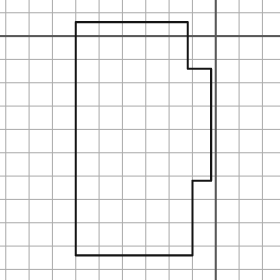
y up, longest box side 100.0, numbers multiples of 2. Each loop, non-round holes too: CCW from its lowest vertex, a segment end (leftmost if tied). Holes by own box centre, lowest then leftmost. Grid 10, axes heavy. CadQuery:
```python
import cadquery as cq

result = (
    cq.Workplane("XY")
    .moveTo(-60.0, -94.0)
    .lineTo(-10.0, -94.0)
    .lineTo(-10.0, -62.0)
    .lineTo(-2.0, -62.0)
    .lineTo(-2.0, -14.0)
    .lineTo(-12.0, -14.0)
    .lineTo(-12.0, 6.0)
    .lineTo(-60.0, 6.0)
    .close()
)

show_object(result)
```